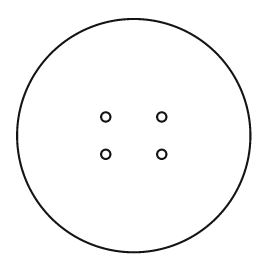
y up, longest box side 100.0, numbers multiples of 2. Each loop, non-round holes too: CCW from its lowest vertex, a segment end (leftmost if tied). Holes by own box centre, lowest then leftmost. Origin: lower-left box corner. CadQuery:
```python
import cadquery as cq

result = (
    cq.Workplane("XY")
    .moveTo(50.0, 50.0)
    .circle(50.0)
    .moveTo(38.0, 42.0)
    .circle(2.0)
    .moveTo(62.0, 42.0)
    .circle(2.0)
    .moveTo(38.0, 58.0)
    .circle(2.0)
    .moveTo(62.0, 58.0)
    .circle(2.0)
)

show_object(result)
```